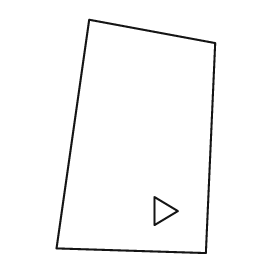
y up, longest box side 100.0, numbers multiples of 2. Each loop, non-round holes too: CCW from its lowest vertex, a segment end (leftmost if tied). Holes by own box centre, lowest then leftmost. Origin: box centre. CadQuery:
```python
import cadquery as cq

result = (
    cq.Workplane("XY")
    .moveTo(30.0, -50.0)
    .lineTo(34.0, 40.0)
    .lineTo(-20.0, 50.0)
    .lineTo(-34.0, -48.0)
    .close()
    .moveTo(8.0, -38.0)
    .lineTo(18.0, -32.0)
    .lineTo(8.0, -26.0)
    .close()
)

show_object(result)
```